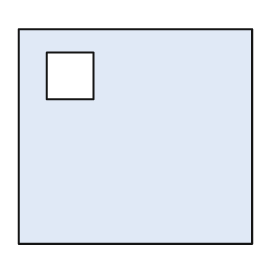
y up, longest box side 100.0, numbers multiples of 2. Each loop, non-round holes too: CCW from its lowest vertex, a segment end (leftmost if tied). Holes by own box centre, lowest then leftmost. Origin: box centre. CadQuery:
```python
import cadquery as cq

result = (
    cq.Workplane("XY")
    .moveTo(-50.0, -46.0)
    .lineTo(50.0, -46.0)
    .lineTo(50.0, 46.0)
    .lineTo(-50.0, 46.0)
    .close()
    .moveTo(-38.0, 16.0)
    .lineTo(-18.0, 16.0)
    .lineTo(-18.0, 36.0)
    .lineTo(-38.0, 36.0)
    .close()
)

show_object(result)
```